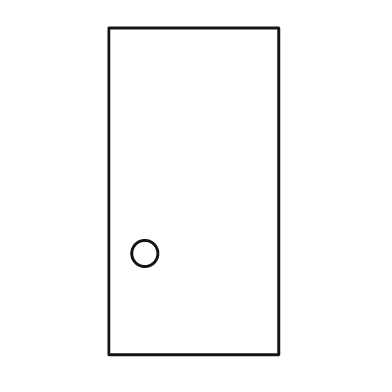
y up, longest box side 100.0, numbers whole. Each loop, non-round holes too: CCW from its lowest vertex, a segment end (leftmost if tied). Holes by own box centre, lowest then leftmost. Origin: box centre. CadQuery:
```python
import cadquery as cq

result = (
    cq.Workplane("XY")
    .moveTo(-26.0, -50.0)
    .lineTo(26.0, -50.0)
    .lineTo(26.0, 50.0)
    .lineTo(-26.0, 50.0)
    .close()
    .moveTo(-15.0, -19.0)
    .circle(4.0)
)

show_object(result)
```